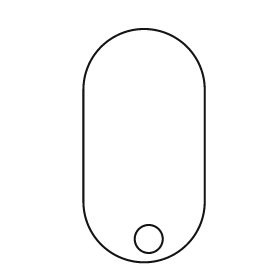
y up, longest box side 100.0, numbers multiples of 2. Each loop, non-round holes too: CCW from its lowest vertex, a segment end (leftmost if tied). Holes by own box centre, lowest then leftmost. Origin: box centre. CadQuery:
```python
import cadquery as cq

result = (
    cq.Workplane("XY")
    .moveTo(-26.0, -24.0)
    .threePointArc((0.0, -50.0), (26.0, -24.0))
    .lineTo(26.0, 24.0)
    .threePointArc((0.0, 50.0), (-26.0, 24.0))
    .close()
    .moveTo(2.0, -40.0)
    .circle(6.0)
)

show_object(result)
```